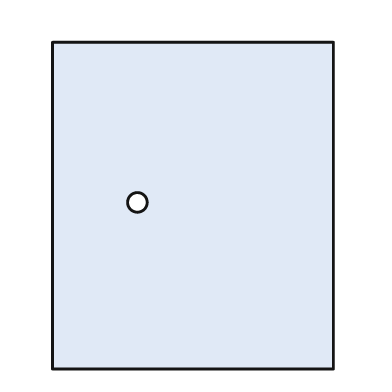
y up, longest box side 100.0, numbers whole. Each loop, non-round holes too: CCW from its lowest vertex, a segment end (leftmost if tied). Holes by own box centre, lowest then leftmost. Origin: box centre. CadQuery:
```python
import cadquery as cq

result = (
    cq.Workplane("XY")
    .moveTo(-43.0, -50.0)
    .lineTo(43.0, -50.0)
    .lineTo(43.0, 50.0)
    .lineTo(-43.0, 50.0)
    .close()
    .moveTo(-17.0, 1.0)
    .circle(3.0)
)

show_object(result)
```